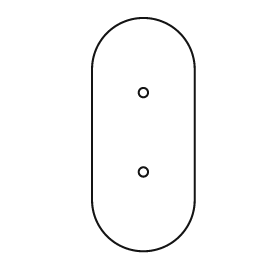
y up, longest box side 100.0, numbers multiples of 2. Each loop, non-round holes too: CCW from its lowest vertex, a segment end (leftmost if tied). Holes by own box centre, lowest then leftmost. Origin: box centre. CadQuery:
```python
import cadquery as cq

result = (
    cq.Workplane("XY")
    .moveTo(-22.0, -28.0)
    .threePointArc((0.0, -50.0), (22.0, -28.0))
    .lineTo(22.0, 28.0)
    .threePointArc((0.0, 50.0), (-22.0, 28.0))
    .close()
    .moveTo(0.0, -16.0)
    .circle(2.0)
    .moveTo(0.0, 18.0)
    .circle(2.0)
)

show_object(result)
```